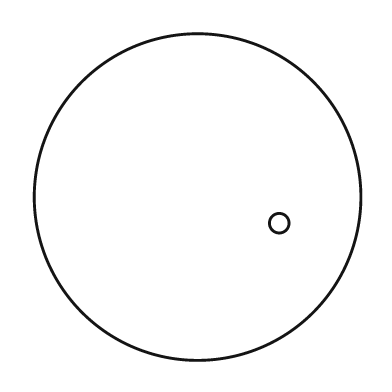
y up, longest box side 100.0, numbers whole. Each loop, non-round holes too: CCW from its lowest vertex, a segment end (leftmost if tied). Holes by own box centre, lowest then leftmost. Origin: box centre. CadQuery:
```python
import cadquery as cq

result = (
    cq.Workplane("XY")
    .moveTo(0.0, 0.0)
    .circle(50.0)
    .moveTo(25.0, -8.0)
    .circle(3.0)
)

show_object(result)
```